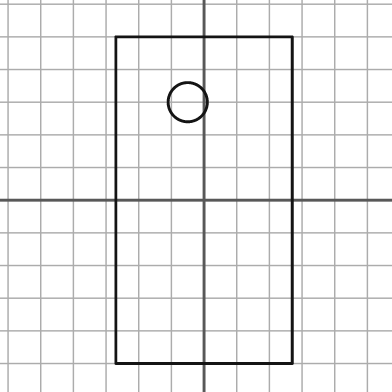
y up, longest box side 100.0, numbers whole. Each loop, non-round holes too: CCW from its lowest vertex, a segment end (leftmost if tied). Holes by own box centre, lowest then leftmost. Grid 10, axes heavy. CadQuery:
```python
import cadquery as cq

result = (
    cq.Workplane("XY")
    .moveTo(-27.0, -50.0)
    .lineTo(27.0, -50.0)
    .lineTo(27.0, 50.0)
    .lineTo(-27.0, 50.0)
    .close()
    .moveTo(-5.0, 30.0)
    .circle(6.0)
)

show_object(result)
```